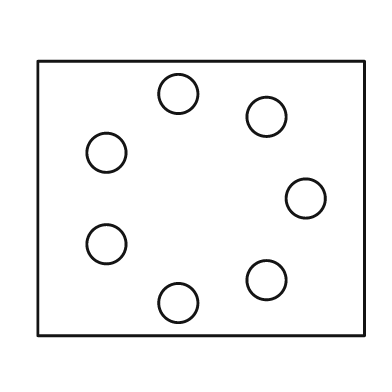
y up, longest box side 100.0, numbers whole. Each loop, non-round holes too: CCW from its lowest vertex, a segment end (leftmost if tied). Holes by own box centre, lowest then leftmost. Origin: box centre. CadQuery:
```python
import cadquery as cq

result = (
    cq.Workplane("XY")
    .moveTo(-50.0, -42.0)
    .lineTo(50.0, -42.0)
    .lineTo(50.0, 42.0)
    .lineTo(-50.0, 42.0)
    .close()
    .moveTo(-7.0, -32.0)
    .circle(6.0)
    .moveTo(20.0, -25.0)
    .circle(6.0)
    .moveTo(-29.0, -14.0)
    .circle(6.0)
    .moveTo(32.0, 0.0)
    .circle(6.0)
    .moveTo(-29.0, 14.0)
    .circle(6.0)
    .moveTo(20.0, 25.0)
    .circle(6.0)
    .moveTo(-7.0, 32.0)
    .circle(6.0)
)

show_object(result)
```